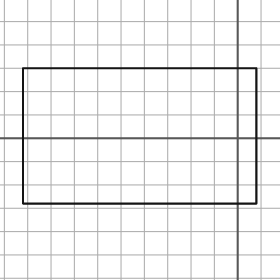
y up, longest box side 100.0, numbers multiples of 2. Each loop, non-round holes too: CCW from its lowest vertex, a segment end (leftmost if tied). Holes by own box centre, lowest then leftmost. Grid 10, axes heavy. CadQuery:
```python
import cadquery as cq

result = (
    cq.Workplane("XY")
    .moveTo(-92.0, -28.0)
    .lineTo(8.0, -28.0)
    .lineTo(8.0, 30.0)
    .lineTo(-92.0, 30.0)
    .close()
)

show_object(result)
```